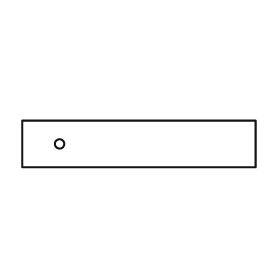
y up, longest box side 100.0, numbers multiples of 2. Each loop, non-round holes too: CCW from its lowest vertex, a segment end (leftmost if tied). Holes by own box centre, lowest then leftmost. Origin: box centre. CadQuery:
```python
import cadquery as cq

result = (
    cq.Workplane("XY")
    .moveTo(-50.0, -10.0)
    .lineTo(50.0, -10.0)
    .lineTo(50.0, 10.0)
    .lineTo(-50.0, 10.0)
    .close()
    .moveTo(-34.0, 0.0)
    .circle(2.0)
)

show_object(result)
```